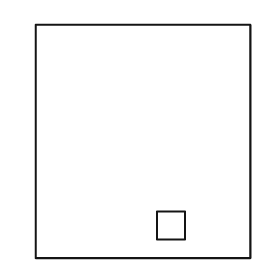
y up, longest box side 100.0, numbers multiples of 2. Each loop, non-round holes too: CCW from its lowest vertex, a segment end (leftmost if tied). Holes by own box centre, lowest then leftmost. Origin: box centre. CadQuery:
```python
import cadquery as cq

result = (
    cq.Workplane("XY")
    .moveTo(-46.0, -50.0)
    .lineTo(46.0, -50.0)
    .lineTo(46.0, 50.0)
    .lineTo(-46.0, 50.0)
    .close()
    .moveTo(6.0, -42.0)
    .lineTo(18.0, -42.0)
    .lineTo(18.0, -30.0)
    .lineTo(6.0, -30.0)
    .close()
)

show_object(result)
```